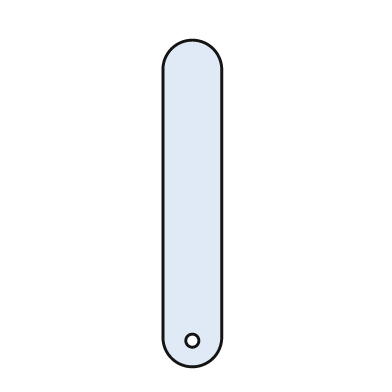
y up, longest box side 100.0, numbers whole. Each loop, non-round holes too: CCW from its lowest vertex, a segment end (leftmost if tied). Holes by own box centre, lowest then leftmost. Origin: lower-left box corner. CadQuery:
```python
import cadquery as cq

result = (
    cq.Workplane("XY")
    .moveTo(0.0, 9.0)
    .threePointArc((9.0, 0.0), (18.0, 9.0))
    .lineTo(18.0, 91.0)
    .threePointArc((9.0, 100.0), (0.0, 91.0))
    .close()
    .moveTo(9.0, 8.0)
    .circle(2.0)
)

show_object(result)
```